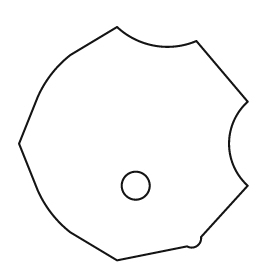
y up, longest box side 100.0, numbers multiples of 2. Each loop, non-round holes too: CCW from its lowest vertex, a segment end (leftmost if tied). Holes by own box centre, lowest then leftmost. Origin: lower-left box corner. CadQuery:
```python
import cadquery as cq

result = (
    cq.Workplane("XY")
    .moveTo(42.0, 0.0)
    .lineTo(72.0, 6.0)
    .threePointArc((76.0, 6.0), (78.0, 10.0))
    .lineTo(98.0, 32.0)
    .threePointArc((90.0, 50.0), (98.0, 68.0))
    .lineTo(76.0, 94.0)
    .threePointArc((58.0, 92.0), (42.0, 100.0))
    .lineTo(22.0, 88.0)
    .threePointArc((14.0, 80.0), (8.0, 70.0))
    .lineTo(0.0, 50.0)
    .lineTo(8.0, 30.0)
    .threePointArc((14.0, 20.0), (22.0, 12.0))
    .close()
    .moveTo(50.0, 32.0)
    .circle(6.0)
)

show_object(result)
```